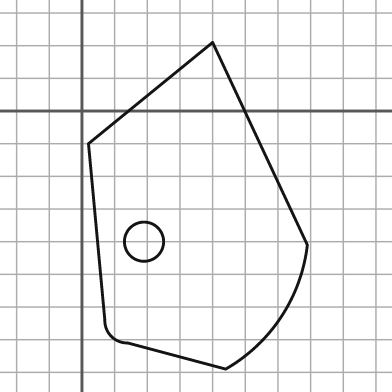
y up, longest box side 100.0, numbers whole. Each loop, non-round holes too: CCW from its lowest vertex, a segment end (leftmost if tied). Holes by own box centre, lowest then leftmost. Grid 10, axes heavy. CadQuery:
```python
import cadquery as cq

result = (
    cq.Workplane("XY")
    .moveTo(44.0, -79.0)
    .threePointArc((61.0, -63.0), (69.0, -41.0))
    .lineTo(40.0, 21.0)
    .lineTo(2.0, -10.0)
    .lineTo(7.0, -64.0)
    .threePointArc((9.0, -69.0), (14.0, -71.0))
    .close()
    .moveTo(19.0, -40.0)
    .circle(6.0)
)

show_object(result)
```